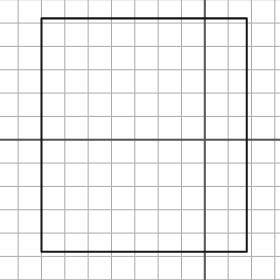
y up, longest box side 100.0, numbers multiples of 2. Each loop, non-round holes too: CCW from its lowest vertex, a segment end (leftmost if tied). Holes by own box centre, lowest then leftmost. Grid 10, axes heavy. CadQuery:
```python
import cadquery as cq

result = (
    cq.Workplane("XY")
    .moveTo(-70.0, -48.0)
    .lineTo(18.0, -48.0)
    .lineTo(18.0, 52.0)
    .lineTo(-70.0, 52.0)
    .close()
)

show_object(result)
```